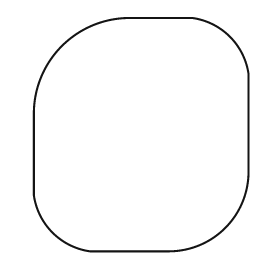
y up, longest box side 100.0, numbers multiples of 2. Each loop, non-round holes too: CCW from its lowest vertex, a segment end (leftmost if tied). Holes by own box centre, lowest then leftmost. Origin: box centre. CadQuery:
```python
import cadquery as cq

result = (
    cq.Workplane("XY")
    .moveTo(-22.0, -50.0)
    .lineTo(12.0, -50.0)
    .threePointArc((36.0, -40.0), (46.0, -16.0))
    .lineTo(46.0, 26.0)
    .threePointArc((38.0, 42.0), (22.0, 50.0))
    .lineTo(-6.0, 50.0)
    .threePointArc((-34.0, 38.0), (-46.0, 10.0))
    .lineTo(-46.0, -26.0)
    .threePointArc((-38.0, -42.0), (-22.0, -50.0))
    .close()
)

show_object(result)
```